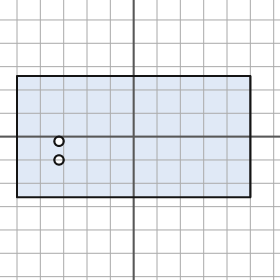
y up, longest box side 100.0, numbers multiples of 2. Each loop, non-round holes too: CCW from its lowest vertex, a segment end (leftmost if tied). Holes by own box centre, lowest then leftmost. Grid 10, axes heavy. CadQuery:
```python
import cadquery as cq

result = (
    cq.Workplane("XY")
    .moveTo(-50.0, -26.0)
    .lineTo(50.0, -26.0)
    .lineTo(50.0, 26.0)
    .lineTo(-50.0, 26.0)
    .close()
    .moveTo(-32.0, -10.0)
    .circle(2.0)
    .moveTo(-32.0, -2.0)
    .circle(2.0)
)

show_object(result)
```